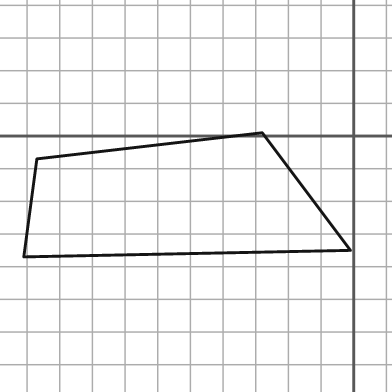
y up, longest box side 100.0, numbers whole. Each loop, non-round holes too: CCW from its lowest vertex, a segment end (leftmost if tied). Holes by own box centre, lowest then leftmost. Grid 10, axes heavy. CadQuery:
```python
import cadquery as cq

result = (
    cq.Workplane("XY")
    .moveTo(-101.0, -37.0)
    .lineTo(-1.0, -35.0)
    .lineTo(-28.0, 1.0)
    .lineTo(-97.0, -7.0)
    .close()
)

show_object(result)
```